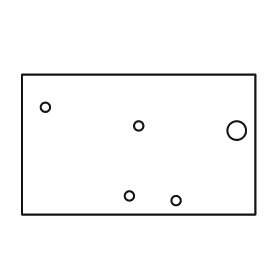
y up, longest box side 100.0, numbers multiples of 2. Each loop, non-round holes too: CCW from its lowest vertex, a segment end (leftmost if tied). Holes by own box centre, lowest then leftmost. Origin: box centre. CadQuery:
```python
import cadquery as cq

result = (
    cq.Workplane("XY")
    .moveTo(-50.0, -30.0)
    .lineTo(50.0, -30.0)
    .lineTo(50.0, 30.0)
    .lineTo(-50.0, 30.0)
    .close()
    .moveTo(16.0, -24.0)
    .circle(2.0)
    .moveTo(-4.0, -22.0)
    .circle(2.0)
    .moveTo(42.0, 6.0)
    .circle(4.0)
    .moveTo(0.0, 8.0)
    .circle(2.0)
    .moveTo(-40.0, 16.0)
    .circle(2.0)
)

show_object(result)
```